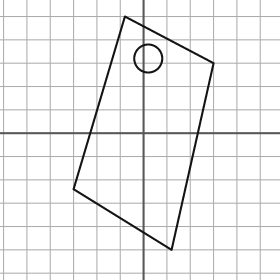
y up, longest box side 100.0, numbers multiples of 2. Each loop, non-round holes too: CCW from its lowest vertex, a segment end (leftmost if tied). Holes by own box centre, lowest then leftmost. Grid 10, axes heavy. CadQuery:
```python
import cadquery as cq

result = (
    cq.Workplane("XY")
    .moveTo(12.0, -50.0)
    .lineTo(30.0, 30.0)
    .lineTo(-8.0, 50.0)
    .lineTo(-30.0, -24.0)
    .close()
    .moveTo(2.0, 32.0)
    .circle(6.0)
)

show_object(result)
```